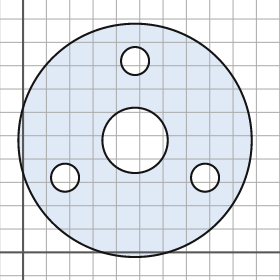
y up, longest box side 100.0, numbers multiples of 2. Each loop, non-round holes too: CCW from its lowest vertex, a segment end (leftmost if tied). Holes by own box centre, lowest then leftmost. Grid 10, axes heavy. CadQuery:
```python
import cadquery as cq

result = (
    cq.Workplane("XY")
    .moveTo(48.0, 48.0)
    .circle(50.0)
    .moveTo(18.0, 32.0)
    .circle(6.0)
    .moveTo(78.0, 32.0)
    .circle(6.0)
    .moveTo(48.0, 48.0)
    .circle(14.0)
    .moveTo(48.0, 82.0)
    .circle(6.0)
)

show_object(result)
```